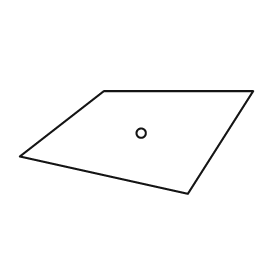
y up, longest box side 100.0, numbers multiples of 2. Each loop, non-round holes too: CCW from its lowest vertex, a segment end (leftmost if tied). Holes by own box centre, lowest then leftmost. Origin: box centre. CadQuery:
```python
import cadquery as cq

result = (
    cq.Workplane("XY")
    .moveTo(22.0, -22.0)
    .lineTo(50.0, 22.0)
    .lineTo(-14.0, 22.0)
    .lineTo(-50.0, -6.0)
    .close()
    .moveTo(2.0, 4.0)
    .circle(2.0)
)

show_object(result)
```